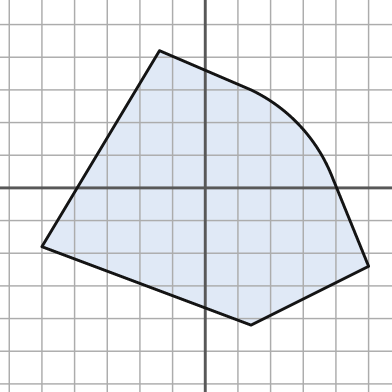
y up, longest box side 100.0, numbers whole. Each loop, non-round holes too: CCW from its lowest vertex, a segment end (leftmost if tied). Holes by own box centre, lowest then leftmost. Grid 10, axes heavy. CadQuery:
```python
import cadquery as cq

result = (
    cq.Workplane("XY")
    .moveTo(14.0, -42.0)
    .lineTo(50.0, -24.0)
    .lineTo(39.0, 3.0)
    .threePointArc((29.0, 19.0), (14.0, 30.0))
    .lineTo(-14.0, 42.0)
    .lineTo(-50.0, -18.0)
    .close()
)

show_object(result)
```